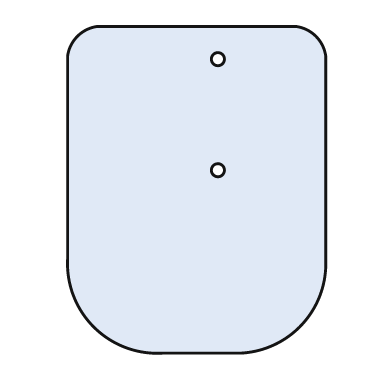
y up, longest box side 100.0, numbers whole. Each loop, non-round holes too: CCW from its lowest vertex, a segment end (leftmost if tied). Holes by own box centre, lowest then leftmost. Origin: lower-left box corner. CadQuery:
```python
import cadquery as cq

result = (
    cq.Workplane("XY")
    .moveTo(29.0, 0.0)
    .lineTo(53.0, 0.0)
    .threePointArc((71.0, 8.0), (79.0, 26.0))
    .lineTo(79.0, 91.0)
    .threePointArc((76.0, 97.0), (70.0, 100.0))
    .lineTo(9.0, 100.0)
    .threePointArc((3.0, 97.0), (0.0, 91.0))
    .lineTo(0.0, 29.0)
    .threePointArc((8.0, 8.0), (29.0, 0.0))
    .close()
    .moveTo(46.0, 56.0)
    .circle(2.0)
    .moveTo(46.0, 90.0)
    .circle(2.0)
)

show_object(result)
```